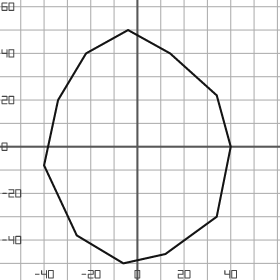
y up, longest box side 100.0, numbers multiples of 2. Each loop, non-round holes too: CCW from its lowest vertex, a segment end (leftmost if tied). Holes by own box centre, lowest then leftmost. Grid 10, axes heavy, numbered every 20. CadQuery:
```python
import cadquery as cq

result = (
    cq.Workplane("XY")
    .moveTo(-6.0, -50.0)
    .lineTo(12.0, -46.0)
    .lineTo(34.0, -30.0)
    .lineTo(40.0, 0.0)
    .lineTo(34.0, 22.0)
    .lineTo(14.0, 40.0)
    .lineTo(-4.0, 50.0)
    .lineTo(-22.0, 40.0)
    .lineTo(-34.0, 20.0)
    .lineTo(-40.0, -8.0)
    .lineTo(-26.0, -38.0)
    .close()
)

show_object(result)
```